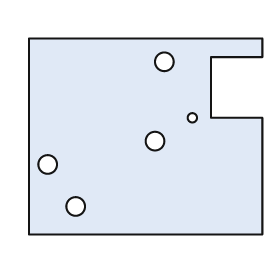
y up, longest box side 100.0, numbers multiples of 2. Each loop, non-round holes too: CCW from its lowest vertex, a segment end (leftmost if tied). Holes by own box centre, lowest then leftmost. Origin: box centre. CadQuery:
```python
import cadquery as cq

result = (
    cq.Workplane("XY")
    .moveTo(-50.0, -42.0)
    .lineTo(50.0, -42.0)
    .lineTo(50.0, 8.0)
    .lineTo(28.0, 8.0)
    .lineTo(28.0, 34.0)
    .lineTo(50.0, 34.0)
    .lineTo(50.0, 42.0)
    .lineTo(-50.0, 42.0)
    .close()
    .moveTo(-30.0, -30.0)
    .circle(4.0)
    .moveTo(-42.0, -12.0)
    .circle(4.0)
    .moveTo(4.0, -2.0)
    .circle(4.0)
    .moveTo(20.0, 8.0)
    .circle(2.0)
    .moveTo(8.0, 32.0)
    .circle(4.0)
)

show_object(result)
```